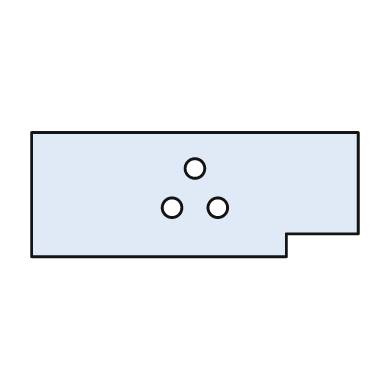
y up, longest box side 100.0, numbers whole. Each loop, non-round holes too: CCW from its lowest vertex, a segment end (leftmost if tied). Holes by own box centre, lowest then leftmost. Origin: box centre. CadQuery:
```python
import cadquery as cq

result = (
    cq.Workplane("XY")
    .moveTo(-50.0, -19.0)
    .lineTo(28.0, -19.0)
    .lineTo(28.0, -12.0)
    .lineTo(50.0, -12.0)
    .lineTo(50.0, 19.0)
    .lineTo(-50.0, 19.0)
    .close()
    .moveTo(-7.0, -4.0)
    .circle(3.0)
    .moveTo(7.0, -4.0)
    .circle(3.0)
    .moveTo(0.0, 8.0)
    .circle(3.0)
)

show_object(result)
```